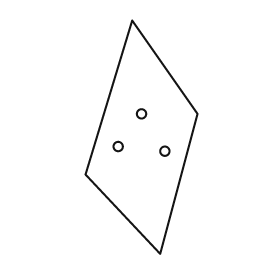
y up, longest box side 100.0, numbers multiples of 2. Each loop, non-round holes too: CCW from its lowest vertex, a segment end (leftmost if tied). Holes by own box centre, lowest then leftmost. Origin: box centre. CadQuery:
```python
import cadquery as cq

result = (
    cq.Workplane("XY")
    .moveTo(8.0, -50.0)
    .lineTo(24.0, 10.0)
    .lineTo(-4.0, 50.0)
    .lineTo(-24.0, -16.0)
    .close()
    .moveTo(10.0, -6.0)
    .circle(2.0)
    .moveTo(-10.0, -4.0)
    .circle(2.0)
    .moveTo(0.0, 10.0)
    .circle(2.0)
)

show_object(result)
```